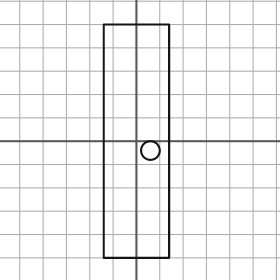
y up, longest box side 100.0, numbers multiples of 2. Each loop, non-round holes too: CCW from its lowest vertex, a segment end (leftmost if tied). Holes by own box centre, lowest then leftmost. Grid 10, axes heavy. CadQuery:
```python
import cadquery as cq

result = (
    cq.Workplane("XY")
    .moveTo(-14.0, -50.0)
    .lineTo(14.0, -50.0)
    .lineTo(14.0, 50.0)
    .lineTo(-14.0, 50.0)
    .close()
    .moveTo(6.0, -4.0)
    .circle(4.0)
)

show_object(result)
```